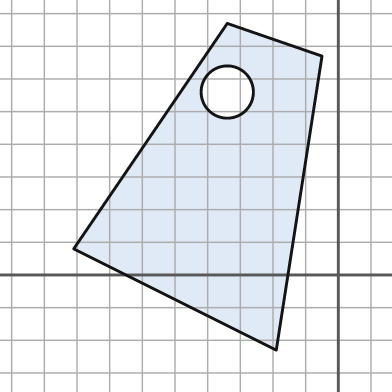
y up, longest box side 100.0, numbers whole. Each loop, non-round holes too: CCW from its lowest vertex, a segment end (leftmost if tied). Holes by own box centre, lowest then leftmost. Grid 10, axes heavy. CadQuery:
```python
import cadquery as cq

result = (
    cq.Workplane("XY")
    .moveTo(-19.0, -23.0)
    .lineTo(-5.0, 67.0)
    .lineTo(-34.0, 77.0)
    .lineTo(-81.0, 8.0)
    .close()
    .moveTo(-34.0, 56.0)
    .circle(8.0)
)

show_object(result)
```